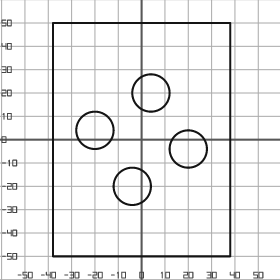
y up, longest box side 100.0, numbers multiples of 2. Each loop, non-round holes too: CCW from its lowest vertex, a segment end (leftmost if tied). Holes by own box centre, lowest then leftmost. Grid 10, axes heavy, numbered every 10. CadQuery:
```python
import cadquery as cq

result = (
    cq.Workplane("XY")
    .moveTo(-38.0, -50.0)
    .lineTo(38.0, -50.0)
    .lineTo(38.0, 50.0)
    .lineTo(-38.0, 50.0)
    .close()
    .moveTo(-4.0, -20.0)
    .circle(8.0)
    .moveTo(20.0, -4.0)
    .circle(8.0)
    .moveTo(-20.0, 4.0)
    .circle(8.0)
    .moveTo(4.0, 20.0)
    .circle(8.0)
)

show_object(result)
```